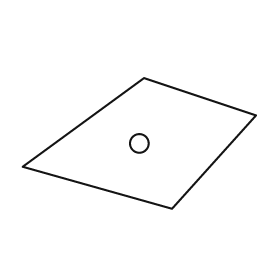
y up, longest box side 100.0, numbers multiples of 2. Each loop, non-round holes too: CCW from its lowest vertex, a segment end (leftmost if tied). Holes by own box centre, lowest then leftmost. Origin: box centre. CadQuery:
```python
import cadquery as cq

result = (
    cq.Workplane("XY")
    .moveTo(14.0, -28.0)
    .lineTo(50.0, 12.0)
    .lineTo(2.0, 28.0)
    .lineTo(-50.0, -10.0)
    .close()
    .moveTo(0.0, 0.0)
    .circle(4.0)
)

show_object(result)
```